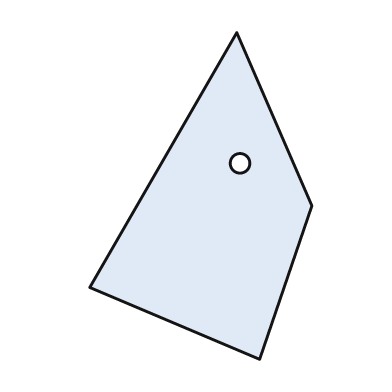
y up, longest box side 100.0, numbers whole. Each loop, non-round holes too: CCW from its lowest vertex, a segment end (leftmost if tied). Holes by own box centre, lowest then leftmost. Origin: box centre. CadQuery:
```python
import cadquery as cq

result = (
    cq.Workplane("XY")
    .moveTo(18.0, -50.0)
    .lineTo(34.0, -3.0)
    .lineTo(11.0, 50.0)
    .lineTo(-34.0, -28.0)
    .close()
    .moveTo(12.0, 10.0)
    .circle(3.0)
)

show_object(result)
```